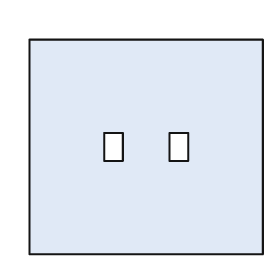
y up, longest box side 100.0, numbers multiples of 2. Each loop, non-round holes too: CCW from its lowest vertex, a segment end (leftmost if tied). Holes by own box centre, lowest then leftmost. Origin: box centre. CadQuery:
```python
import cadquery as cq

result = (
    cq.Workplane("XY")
    .moveTo(-50.0, -46.0)
    .lineTo(50.0, -46.0)
    .lineTo(50.0, 46.0)
    .lineTo(-50.0, 46.0)
    .close()
    .moveTo(-18.0, -6.0)
    .lineTo(-10.0, -6.0)
    .lineTo(-10.0, 6.0)
    .lineTo(-18.0, 6.0)
    .close()
    .moveTo(10.0, -6.0)
    .lineTo(18.0, -6.0)
    .lineTo(18.0, 6.0)
    .lineTo(10.0, 6.0)
    .close()
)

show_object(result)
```